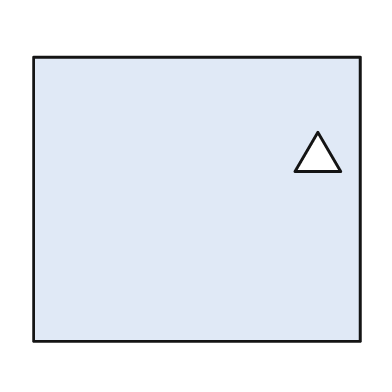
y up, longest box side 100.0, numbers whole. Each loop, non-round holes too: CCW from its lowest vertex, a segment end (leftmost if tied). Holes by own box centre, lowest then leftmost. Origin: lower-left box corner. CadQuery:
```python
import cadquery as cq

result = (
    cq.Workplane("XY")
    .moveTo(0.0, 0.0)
    .lineTo(100.0, 0.0)
    .lineTo(100.0, 87.0)
    .lineTo(0.0, 87.0)
    .close()
    .moveTo(80.0, 52.0)
    .lineTo(94.0, 52.0)
    .lineTo(87.0, 64.0)
    .close()
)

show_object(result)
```